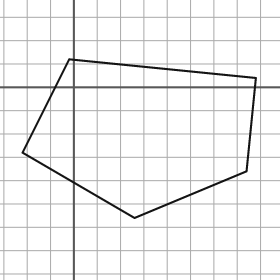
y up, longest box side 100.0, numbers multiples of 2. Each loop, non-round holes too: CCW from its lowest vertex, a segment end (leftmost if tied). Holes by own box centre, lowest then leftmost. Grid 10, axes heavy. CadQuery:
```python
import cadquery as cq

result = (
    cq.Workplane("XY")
    .moveTo(26.0, -56.0)
    .lineTo(74.0, -36.0)
    .lineTo(78.0, 4.0)
    .lineTo(-2.0, 12.0)
    .lineTo(-22.0, -28.0)
    .close()
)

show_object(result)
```